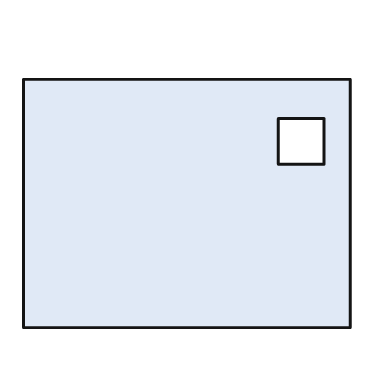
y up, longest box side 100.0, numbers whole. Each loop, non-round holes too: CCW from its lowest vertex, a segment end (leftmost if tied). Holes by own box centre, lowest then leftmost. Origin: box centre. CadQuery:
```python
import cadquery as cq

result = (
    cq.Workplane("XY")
    .moveTo(-50.0, -38.0)
    .lineTo(50.0, -38.0)
    .lineTo(50.0, 38.0)
    .lineTo(-50.0, 38.0)
    .close()
    .moveTo(28.0, 12.0)
    .lineTo(42.0, 12.0)
    .lineTo(42.0, 26.0)
    .lineTo(28.0, 26.0)
    .close()
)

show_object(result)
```